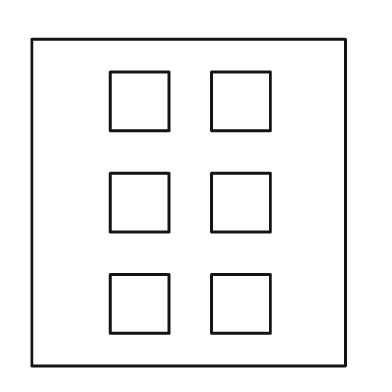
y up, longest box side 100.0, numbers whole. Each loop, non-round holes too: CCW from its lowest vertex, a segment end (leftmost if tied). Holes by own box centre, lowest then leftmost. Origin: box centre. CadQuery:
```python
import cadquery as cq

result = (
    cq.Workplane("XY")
    .moveTo(-48.0, -50.0)
    .lineTo(48.0, -50.0)
    .lineTo(48.0, 50.0)
    .lineTo(-48.0, 50.0)
    .close()
    .moveTo(-24.0, -40.0)
    .lineTo(-6.0, -40.0)
    .lineTo(-6.0, -22.0)
    .lineTo(-24.0, -22.0)
    .close()
    .moveTo(7.0, -40.0)
    .lineTo(25.0, -40.0)
    .lineTo(25.0, -22.0)
    .lineTo(7.0, -22.0)
    .close()
    .moveTo(-24.0, -9.0)
    .lineTo(-6.0, -9.0)
    .lineTo(-6.0, 9.0)
    .lineTo(-24.0, 9.0)
    .close()
    .moveTo(7.0, -9.0)
    .lineTo(25.0, -9.0)
    .lineTo(25.0, 9.0)
    .lineTo(7.0, 9.0)
    .close()
    .moveTo(-24.0, 22.0)
    .lineTo(-6.0, 22.0)
    .lineTo(-6.0, 40.0)
    .lineTo(-24.0, 40.0)
    .close()
    .moveTo(7.0, 22.0)
    .lineTo(25.0, 22.0)
    .lineTo(25.0, 40.0)
    .lineTo(7.0, 40.0)
    .close()
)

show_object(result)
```